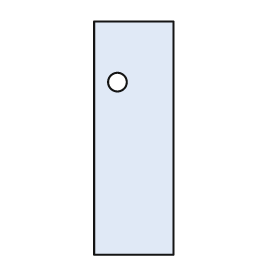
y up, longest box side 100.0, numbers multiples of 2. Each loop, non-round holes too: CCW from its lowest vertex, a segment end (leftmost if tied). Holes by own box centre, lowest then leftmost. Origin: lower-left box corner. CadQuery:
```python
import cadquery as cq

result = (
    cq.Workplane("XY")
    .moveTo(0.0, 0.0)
    .lineTo(34.0, 0.0)
    .lineTo(34.0, 100.0)
    .lineTo(0.0, 100.0)
    .close()
    .moveTo(10.0, 74.0)
    .circle(4.0)
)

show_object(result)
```